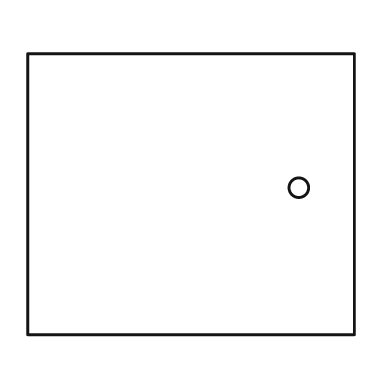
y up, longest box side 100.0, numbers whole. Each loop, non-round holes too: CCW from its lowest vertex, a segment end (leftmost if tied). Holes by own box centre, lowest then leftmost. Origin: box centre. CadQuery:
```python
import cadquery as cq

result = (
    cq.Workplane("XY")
    .moveTo(-50.0, -43.0)
    .lineTo(50.0, -43.0)
    .lineTo(50.0, 43.0)
    .lineTo(-50.0, 43.0)
    .close()
    .moveTo(33.0, 2.0)
    .circle(3.0)
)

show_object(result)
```